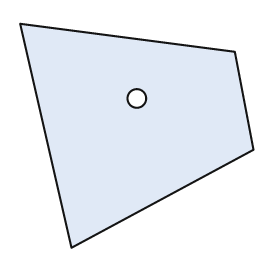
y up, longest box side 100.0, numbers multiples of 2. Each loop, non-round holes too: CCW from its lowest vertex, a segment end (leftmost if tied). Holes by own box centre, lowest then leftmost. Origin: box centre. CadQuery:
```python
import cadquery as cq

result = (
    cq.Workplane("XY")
    .moveTo(-28.0, -48.0)
    .lineTo(50.0, -6.0)
    .lineTo(42.0, 36.0)
    .lineTo(-50.0, 48.0)
    .close()
    .moveTo(0.0, 16.0)
    .circle(4.0)
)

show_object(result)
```